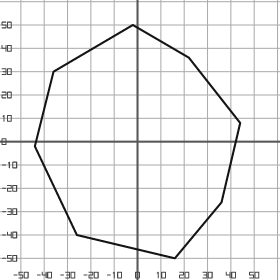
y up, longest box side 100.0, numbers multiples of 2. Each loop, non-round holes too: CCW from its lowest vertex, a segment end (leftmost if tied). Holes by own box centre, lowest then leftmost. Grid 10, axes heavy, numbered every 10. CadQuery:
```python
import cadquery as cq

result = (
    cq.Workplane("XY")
    .moveTo(16.0, -50.0)
    .lineTo(36.0, -26.0)
    .lineTo(44.0, 8.0)
    .lineTo(22.0, 36.0)
    .lineTo(-2.0, 50.0)
    .lineTo(-36.0, 30.0)
    .lineTo(-44.0, -2.0)
    .lineTo(-26.0, -40.0)
    .close()
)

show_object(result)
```